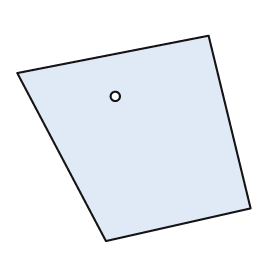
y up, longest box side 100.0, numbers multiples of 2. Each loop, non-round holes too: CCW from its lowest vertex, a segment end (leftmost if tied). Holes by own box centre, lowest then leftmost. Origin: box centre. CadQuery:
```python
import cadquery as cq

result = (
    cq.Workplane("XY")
    .moveTo(-12.0, -44.0)
    .lineTo(50.0, -30.0)
    .lineTo(32.0, 44.0)
    .lineTo(-50.0, 28.0)
    .close()
    .moveTo(-8.0, 18.0)
    .circle(2.0)
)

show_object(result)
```